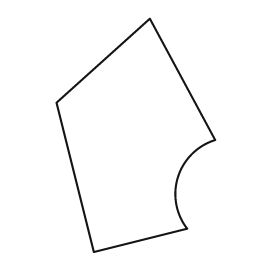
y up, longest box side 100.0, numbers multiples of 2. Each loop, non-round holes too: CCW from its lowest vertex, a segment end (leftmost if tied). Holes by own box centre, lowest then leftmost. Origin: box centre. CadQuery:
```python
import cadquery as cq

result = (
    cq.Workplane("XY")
    .moveTo(-18.0, -50.0)
    .lineTo(22.0, -40.0)
    .threePointArc((18.0, -18.0), (34.0, -2.0))
    .lineTo(6.0, 50.0)
    .lineTo(-34.0, 14.0)
    .close()
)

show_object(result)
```